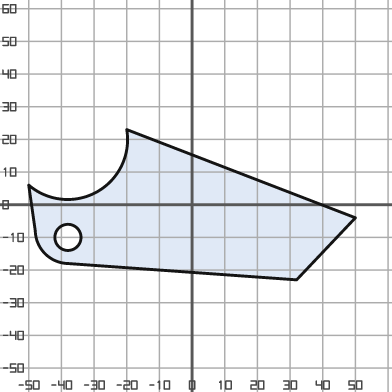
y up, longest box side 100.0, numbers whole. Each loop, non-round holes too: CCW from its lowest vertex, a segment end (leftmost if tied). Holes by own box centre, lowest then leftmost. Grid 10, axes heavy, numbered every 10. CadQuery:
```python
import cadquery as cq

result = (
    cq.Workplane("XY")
    .moveTo(32.0, -23.0)
    .lineTo(50.0, -4.0)
    .lineTo(-20.0, 23.0)
    .threePointArc((-29.0, 4.0), (-50.0, 6.0))
    .lineTo(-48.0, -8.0)
    .threePointArc((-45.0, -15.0), (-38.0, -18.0))
    .close()
    .moveTo(-38.0, -10.0)
    .circle(4.0)
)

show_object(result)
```